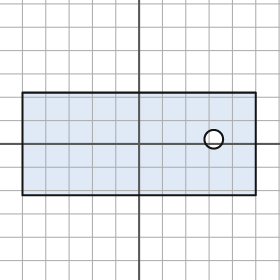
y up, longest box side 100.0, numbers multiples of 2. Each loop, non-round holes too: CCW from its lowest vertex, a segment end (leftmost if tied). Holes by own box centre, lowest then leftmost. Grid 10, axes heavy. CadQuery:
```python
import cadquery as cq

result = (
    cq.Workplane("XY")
    .moveTo(-50.0, -22.0)
    .lineTo(50.0, -22.0)
    .lineTo(50.0, 22.0)
    .lineTo(-50.0, 22.0)
    .close()
    .moveTo(32.0, 2.0)
    .circle(4.0)
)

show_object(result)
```